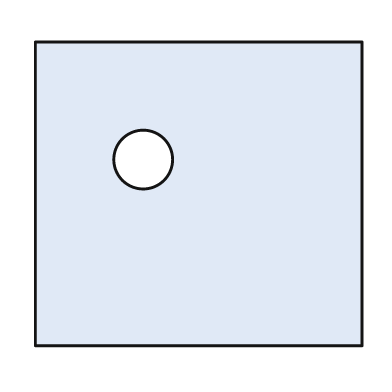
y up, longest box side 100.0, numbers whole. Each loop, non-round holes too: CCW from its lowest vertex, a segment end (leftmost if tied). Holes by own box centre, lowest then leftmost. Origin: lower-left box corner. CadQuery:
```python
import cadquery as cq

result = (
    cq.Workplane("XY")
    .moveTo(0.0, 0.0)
    .lineTo(100.0, 0.0)
    .lineTo(100.0, 93.0)
    .lineTo(0.0, 93.0)
    .close()
    .moveTo(33.0, 57.0)
    .circle(9.0)
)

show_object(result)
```